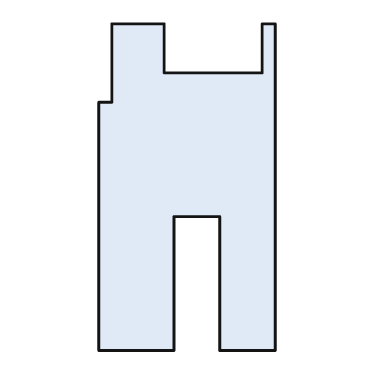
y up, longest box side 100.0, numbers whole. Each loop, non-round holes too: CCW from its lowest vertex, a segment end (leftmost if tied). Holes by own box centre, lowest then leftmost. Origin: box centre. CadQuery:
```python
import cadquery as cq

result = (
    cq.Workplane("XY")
    .moveTo(-27.0, -50.0)
    .lineTo(-4.0, -50.0)
    .lineTo(-4.0, -9.0)
    .lineTo(10.0, -9.0)
    .lineTo(10.0, -50.0)
    .lineTo(27.0, -50.0)
    .lineTo(27.0, 50.0)
    .lineTo(23.0, 50.0)
    .lineTo(23.0, 35.0)
    .lineTo(-7.0, 35.0)
    .lineTo(-7.0, 50.0)
    .lineTo(-23.0, 50.0)
    .lineTo(-23.0, 26.0)
    .lineTo(-27.0, 26.0)
    .close()
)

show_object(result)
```